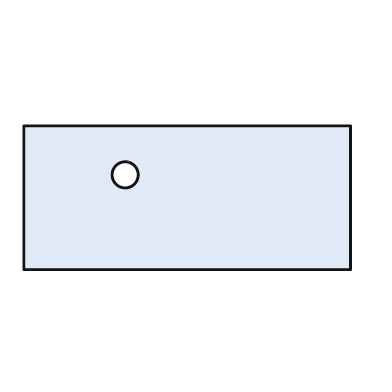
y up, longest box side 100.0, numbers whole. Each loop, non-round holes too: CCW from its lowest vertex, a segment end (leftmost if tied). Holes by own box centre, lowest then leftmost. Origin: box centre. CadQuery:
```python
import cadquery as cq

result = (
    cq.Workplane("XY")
    .moveTo(-50.0, -22.0)
    .lineTo(50.0, -22.0)
    .lineTo(50.0, 22.0)
    .lineTo(-50.0, 22.0)
    .close()
    .moveTo(-19.0, 7.0)
    .circle(4.0)
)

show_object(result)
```